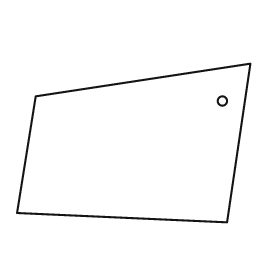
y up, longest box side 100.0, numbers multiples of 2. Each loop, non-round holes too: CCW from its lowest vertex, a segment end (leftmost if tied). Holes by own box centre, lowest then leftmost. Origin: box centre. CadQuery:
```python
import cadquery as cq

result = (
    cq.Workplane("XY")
    .moveTo(40.0, -34.0)
    .lineTo(50.0, 34.0)
    .lineTo(-42.0, 20.0)
    .lineTo(-50.0, -30.0)
    .close()
    .moveTo(38.0, 18.0)
    .circle(2.0)
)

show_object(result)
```